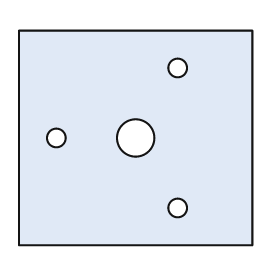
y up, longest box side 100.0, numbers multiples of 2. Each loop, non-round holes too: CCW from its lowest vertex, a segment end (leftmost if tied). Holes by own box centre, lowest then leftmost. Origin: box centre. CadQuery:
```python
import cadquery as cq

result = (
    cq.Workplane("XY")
    .moveTo(-50.0, -46.0)
    .lineTo(50.0, -46.0)
    .lineTo(50.0, 46.0)
    .lineTo(-50.0, 46.0)
    .close()
    .moveTo(18.0, -30.0)
    .circle(4.0)
    .moveTo(-34.0, 0.0)
    .circle(4.0)
    .moveTo(0.0, 0.0)
    .circle(8.0)
    .moveTo(18.0, 30.0)
    .circle(4.0)
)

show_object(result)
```